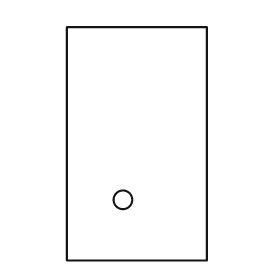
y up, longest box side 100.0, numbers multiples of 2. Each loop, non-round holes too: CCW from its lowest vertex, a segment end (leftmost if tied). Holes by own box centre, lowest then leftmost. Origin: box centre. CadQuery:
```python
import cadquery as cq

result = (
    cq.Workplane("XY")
    .moveTo(-30.0, -50.0)
    .lineTo(30.0, -50.0)
    .lineTo(30.0, 50.0)
    .lineTo(-30.0, 50.0)
    .close()
    .moveTo(-6.0, -24.0)
    .circle(4.0)
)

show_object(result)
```